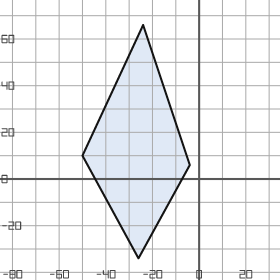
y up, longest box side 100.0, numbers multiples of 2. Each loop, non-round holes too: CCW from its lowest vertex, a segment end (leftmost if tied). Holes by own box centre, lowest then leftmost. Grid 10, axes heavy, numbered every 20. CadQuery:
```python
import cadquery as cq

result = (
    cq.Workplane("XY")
    .moveTo(-26.0, -34.0)
    .lineTo(-4.0, 6.0)
    .lineTo(-24.0, 66.0)
    .lineTo(-50.0, 10.0)
    .close()
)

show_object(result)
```